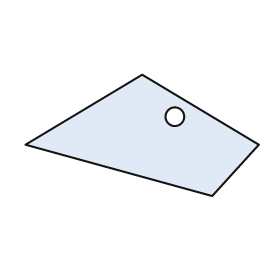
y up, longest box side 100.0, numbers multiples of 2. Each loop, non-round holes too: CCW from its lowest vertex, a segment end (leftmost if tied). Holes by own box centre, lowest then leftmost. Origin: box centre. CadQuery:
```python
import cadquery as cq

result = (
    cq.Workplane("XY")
    .moveTo(30.0, -26.0)
    .lineTo(50.0, -4.0)
    .lineTo(0.0, 26.0)
    .lineTo(-50.0, -4.0)
    .close()
    .moveTo(14.0, 8.0)
    .circle(4.0)
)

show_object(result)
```